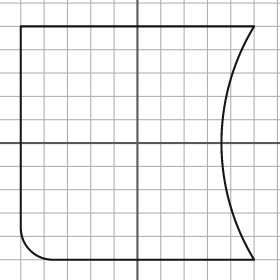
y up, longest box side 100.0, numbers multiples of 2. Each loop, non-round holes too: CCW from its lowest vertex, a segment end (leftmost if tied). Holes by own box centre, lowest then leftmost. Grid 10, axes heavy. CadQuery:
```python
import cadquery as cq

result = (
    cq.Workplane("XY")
    .moveTo(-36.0, -50.0)
    .lineTo(50.0, -50.0)
    .threePointArc((36.0, 0.0), (50.0, 50.0))
    .lineTo(-50.0, 50.0)
    .lineTo(-50.0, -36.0)
    .threePointArc((-46.0, -46.0), (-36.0, -50.0))
    .close()
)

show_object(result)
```